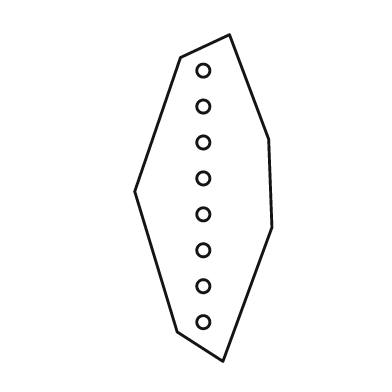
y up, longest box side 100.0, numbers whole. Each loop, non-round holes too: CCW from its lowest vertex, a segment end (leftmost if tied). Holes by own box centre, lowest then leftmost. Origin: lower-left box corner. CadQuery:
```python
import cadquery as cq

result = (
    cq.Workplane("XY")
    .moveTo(27.0, 0.0)
    .lineTo(42.0, 41.0)
    .lineTo(41.0, 68.0)
    .lineTo(29.0, 100.0)
    .lineTo(14.0, 93.0)
    .lineTo(0.0, 52.0)
    .lineTo(13.0, 9.0)
    .close()
    .moveTo(21.0, 12.0)
    .circle(2.0)
    .moveTo(21.0, 23.0)
    .circle(2.0)
    .moveTo(21.0, 34.0)
    .circle(2.0)
    .moveTo(21.0, 45.0)
    .circle(2.0)
    .moveTo(21.0, 56.0)
    .circle(2.0)
    .moveTo(21.0, 67.0)
    .circle(2.0)
    .moveTo(21.0, 78.0)
    .circle(2.0)
    .moveTo(21.0, 89.0)
    .circle(2.0)
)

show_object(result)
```